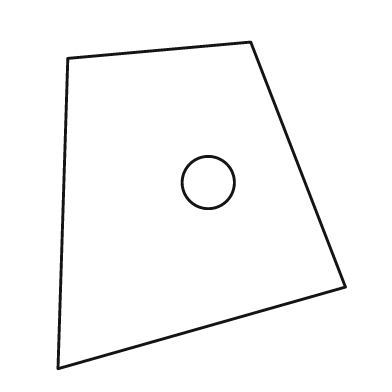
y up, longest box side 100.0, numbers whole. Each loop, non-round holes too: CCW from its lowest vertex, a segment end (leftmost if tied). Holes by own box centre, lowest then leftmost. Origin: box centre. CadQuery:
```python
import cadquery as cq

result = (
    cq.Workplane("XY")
    .moveTo(-44.0, -50.0)
    .lineTo(44.0, -25.0)
    .lineTo(15.0, 50.0)
    .lineTo(-41.0, 45.0)
    .close()
    .moveTo(2.0, 7.0)
    .circle(8.0)
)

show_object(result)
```